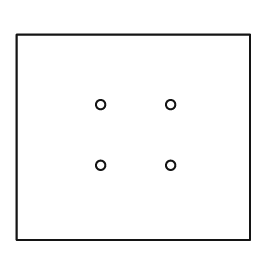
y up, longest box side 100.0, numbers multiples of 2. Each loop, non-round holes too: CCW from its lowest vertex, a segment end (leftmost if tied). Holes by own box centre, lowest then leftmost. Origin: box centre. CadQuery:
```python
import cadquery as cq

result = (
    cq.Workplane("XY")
    .moveTo(-50.0, -44.0)
    .lineTo(50.0, -44.0)
    .lineTo(50.0, 44.0)
    .lineTo(-50.0, 44.0)
    .close()
    .moveTo(-14.0, -12.0)
    .circle(2.0)
    .moveTo(16.0, -12.0)
    .circle(2.0)
    .moveTo(-14.0, 14.0)
    .circle(2.0)
    .moveTo(16.0, 14.0)
    .circle(2.0)
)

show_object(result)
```